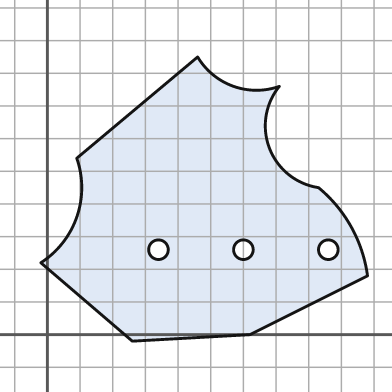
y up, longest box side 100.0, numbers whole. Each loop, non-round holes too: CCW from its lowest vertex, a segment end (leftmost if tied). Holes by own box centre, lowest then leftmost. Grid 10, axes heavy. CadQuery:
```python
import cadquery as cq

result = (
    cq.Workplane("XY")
    .moveTo(26.0, -2.0)
    .lineTo(62.0, 0.0)
    .lineTo(98.0, 18.0)
    .threePointArc((93.0, 33.0), (83.0, 45.0))
    .threePointArc((68.0, 57.0), (71.0, 76.0))
    .threePointArc((57.0, 76.0), (46.0, 85.0))
    .lineTo(9.0, 54.0)
    .threePointArc((9.0, 36.0), (-2.0, 22.0))
    .close()
    .moveTo(34.0, 26.0)
    .circle(3.0)
    .moveTo(60.0, 26.0)
    .circle(3.0)
    .moveTo(86.0, 26.0)
    .circle(3.0)
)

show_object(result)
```